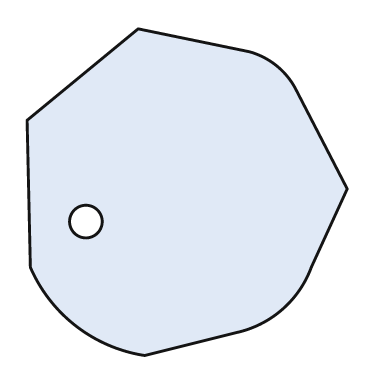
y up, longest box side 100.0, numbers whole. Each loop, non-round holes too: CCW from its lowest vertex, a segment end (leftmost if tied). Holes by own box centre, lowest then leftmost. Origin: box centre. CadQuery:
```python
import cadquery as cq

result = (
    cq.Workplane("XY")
    .moveTo(-13.0, -50.0)
    .lineTo(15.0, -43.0)
    .threePointArc((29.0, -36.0), (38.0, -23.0))
    .lineTo(49.0, 1.0)
    .lineTo(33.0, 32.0)
    .threePointArc((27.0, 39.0), (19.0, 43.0))
    .lineTo(-15.0, 50.0)
    .lineTo(-49.0, 22.0)
    .lineTo(-48.0, -23.0)
    .threePointArc((-34.0, -41.0), (-13.0, -50.0))
    .close()
    .moveTo(-31.0, -9.0)
    .circle(5.0)
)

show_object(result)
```